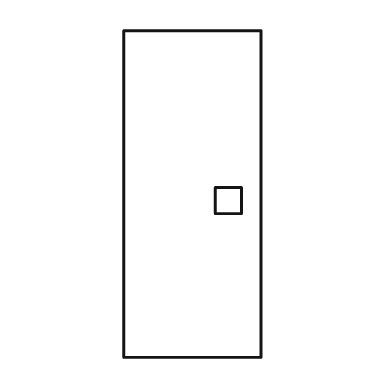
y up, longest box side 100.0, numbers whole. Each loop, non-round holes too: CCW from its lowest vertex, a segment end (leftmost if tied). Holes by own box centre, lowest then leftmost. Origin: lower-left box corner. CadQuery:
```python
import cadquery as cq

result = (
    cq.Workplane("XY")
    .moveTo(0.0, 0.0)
    .lineTo(42.0, 0.0)
    .lineTo(42.0, 100.0)
    .lineTo(0.0, 100.0)
    .close()
    .moveTo(28.0, 44.0)
    .lineTo(36.0, 44.0)
    .lineTo(36.0, 52.0)
    .lineTo(28.0, 52.0)
    .close()
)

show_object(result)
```